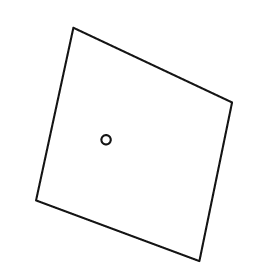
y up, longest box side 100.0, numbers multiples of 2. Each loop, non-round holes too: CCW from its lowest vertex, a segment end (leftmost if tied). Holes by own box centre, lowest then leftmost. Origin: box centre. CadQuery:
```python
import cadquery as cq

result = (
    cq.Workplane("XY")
    .moveTo(28.0, -50.0)
    .lineTo(42.0, 18.0)
    .lineTo(-26.0, 50.0)
    .lineTo(-42.0, -24.0)
    .close()
    .moveTo(-12.0, 2.0)
    .circle(2.0)
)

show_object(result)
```